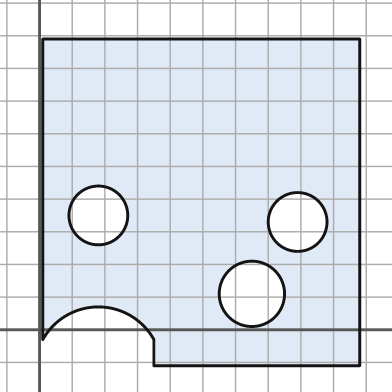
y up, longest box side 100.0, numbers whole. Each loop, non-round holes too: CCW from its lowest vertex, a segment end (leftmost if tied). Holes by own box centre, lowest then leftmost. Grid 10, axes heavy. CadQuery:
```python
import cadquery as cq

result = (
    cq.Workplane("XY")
    .moveTo(35.0, -11.0)
    .lineTo(98.0, -11.0)
    .lineTo(98.0, 89.0)
    .lineTo(1.0, 89.0)
    .lineTo(1.0, -3.0)
    .threePointArc((18.0, 7.0), (35.0, -3.0))
    .close()
    .moveTo(65.0, 11.0)
    .circle(10.0)
    .moveTo(79.0, 33.0)
    .circle(9.0)
    .moveTo(18.0, 35.0)
    .circle(9.0)
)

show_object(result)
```